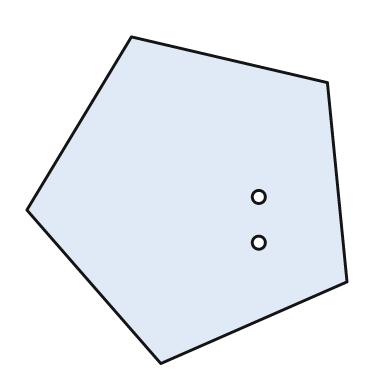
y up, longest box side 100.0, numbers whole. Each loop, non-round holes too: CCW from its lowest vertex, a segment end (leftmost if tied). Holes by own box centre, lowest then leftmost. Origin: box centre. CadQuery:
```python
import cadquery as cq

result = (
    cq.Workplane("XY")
    .moveTo(-8.0, -50.0)
    .lineTo(49.0, -25.0)
    .lineTo(43.0, 36.0)
    .lineTo(-17.0, 50.0)
    .lineTo(-49.0, -3.0)
    .close()
    .moveTo(22.0, -13.0)
    .circle(2.0)
    .moveTo(22.0, 1.0)
    .circle(2.0)
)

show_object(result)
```